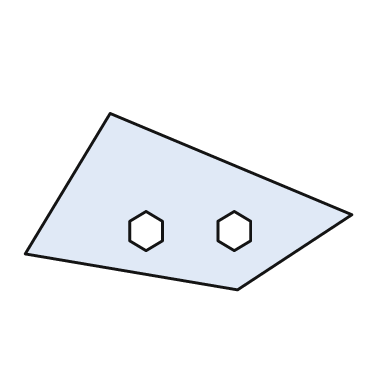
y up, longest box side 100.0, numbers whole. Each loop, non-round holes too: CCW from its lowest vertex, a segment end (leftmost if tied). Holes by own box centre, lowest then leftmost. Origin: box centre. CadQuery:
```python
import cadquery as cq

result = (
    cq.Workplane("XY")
    .moveTo(15.0, -27.0)
    .lineTo(50.0, -4.0)
    .lineTo(-24.0, 27.0)
    .lineTo(-50.0, -16.0)
    .close()
    .moveTo(-13.0, -15.0)
    .lineTo(-8.0, -12.0)
    .lineTo(-8.0, -6.0)
    .lineTo(-13.0, -3.0)
    .lineTo(-18.0, -6.0)
    .lineTo(-18.0, -12.0)
    .close()
    .moveTo(14.0, -15.0)
    .lineTo(19.0, -12.0)
    .lineTo(19.0, -6.0)
    .lineTo(14.0, -3.0)
    .lineTo(9.0, -6.0)
    .lineTo(9.0, -12.0)
    .close()
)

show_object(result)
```